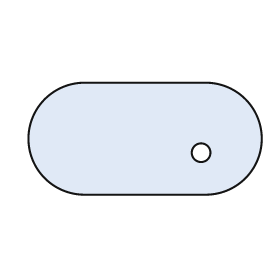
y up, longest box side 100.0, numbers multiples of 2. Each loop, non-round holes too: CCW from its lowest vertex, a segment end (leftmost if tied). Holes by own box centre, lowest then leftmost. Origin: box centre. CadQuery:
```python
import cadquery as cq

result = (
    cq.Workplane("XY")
    .moveTo(-26.0, -24.0)
    .lineTo(26.0, -24.0)
    .threePointArc((50.0, 0.0), (26.0, 24.0))
    .lineTo(-26.0, 24.0)
    .threePointArc((-50.0, 0.0), (-26.0, -24.0))
    .close()
    .moveTo(24.0, -6.0)
    .circle(4.0)
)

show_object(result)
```